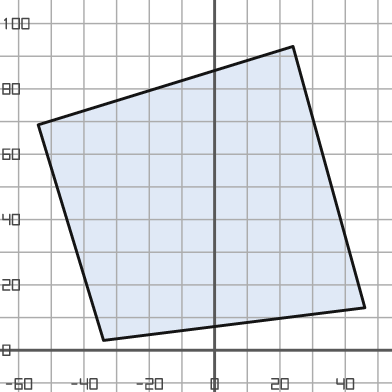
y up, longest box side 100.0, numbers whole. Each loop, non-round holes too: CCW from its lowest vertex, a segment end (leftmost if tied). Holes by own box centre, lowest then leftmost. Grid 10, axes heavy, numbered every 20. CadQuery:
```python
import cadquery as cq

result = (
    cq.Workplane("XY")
    .moveTo(-34.0, 3.0)
    .lineTo(46.0, 13.0)
    .lineTo(24.0, 93.0)
    .lineTo(-54.0, 69.0)
    .close()
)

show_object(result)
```